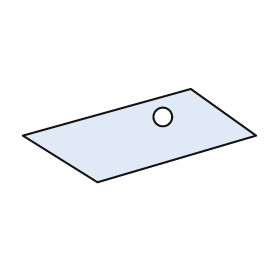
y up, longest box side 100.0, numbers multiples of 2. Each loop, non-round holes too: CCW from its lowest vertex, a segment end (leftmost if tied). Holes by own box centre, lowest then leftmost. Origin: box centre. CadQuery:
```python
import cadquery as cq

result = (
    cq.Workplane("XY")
    .moveTo(-18.0, -20.0)
    .lineTo(50.0, 0.0)
    .lineTo(22.0, 20.0)
    .lineTo(-50.0, 0.0)
    .close()
    .moveTo(10.0, 8.0)
    .circle(4.0)
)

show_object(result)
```